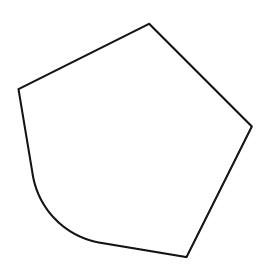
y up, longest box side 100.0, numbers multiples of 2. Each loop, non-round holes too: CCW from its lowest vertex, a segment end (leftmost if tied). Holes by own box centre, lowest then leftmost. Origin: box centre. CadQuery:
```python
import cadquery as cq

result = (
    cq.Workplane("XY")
    .moveTo(22.0, -50.0)
    .lineTo(50.0, 6.0)
    .lineTo(6.0, 50.0)
    .lineTo(-50.0, 22.0)
    .lineTo(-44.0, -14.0)
    .threePointArc((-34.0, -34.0), (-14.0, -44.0))
    .close()
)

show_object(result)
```